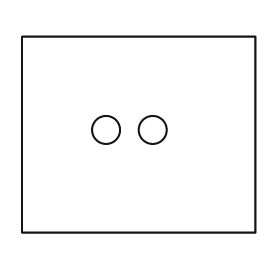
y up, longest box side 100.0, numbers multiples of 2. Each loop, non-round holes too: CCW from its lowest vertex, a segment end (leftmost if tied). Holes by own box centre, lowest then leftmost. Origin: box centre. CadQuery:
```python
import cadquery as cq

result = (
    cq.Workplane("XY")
    .moveTo(-50.0, -42.0)
    .lineTo(50.0, -42.0)
    .lineTo(50.0, 42.0)
    .lineTo(-50.0, 42.0)
    .close()
    .moveTo(-14.0, 2.0)
    .circle(6.0)
    .moveTo(6.0, 2.0)
    .circle(6.0)
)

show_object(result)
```